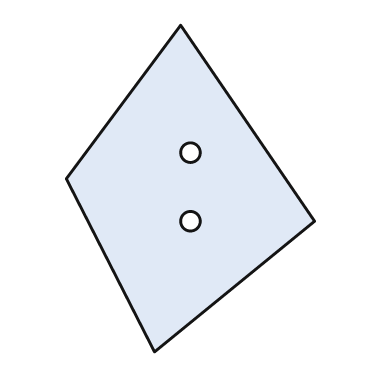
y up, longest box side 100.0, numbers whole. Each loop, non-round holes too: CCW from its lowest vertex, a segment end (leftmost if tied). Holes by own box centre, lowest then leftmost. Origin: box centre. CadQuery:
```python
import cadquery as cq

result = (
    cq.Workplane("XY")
    .moveTo(-11.0, -50.0)
    .lineTo(38.0, -10.0)
    .lineTo(-3.0, 50.0)
    .lineTo(-38.0, 3.0)
    .close()
    .moveTo(0.0, -10.0)
    .circle(3.0)
    .moveTo(0.0, 11.0)
    .circle(3.0)
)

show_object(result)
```